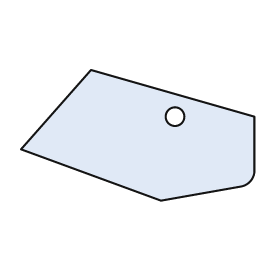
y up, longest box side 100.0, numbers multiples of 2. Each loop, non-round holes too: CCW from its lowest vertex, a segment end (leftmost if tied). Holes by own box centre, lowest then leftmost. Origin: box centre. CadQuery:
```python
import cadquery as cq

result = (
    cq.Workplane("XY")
    .moveTo(10.0, -28.0)
    .lineTo(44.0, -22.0)
    .threePointArc((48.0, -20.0), (50.0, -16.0))
    .lineTo(50.0, 8.0)
    .lineTo(-20.0, 28.0)
    .lineTo(-50.0, -6.0)
    .close()
    .moveTo(16.0, 8.0)
    .circle(4.0)
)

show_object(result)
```